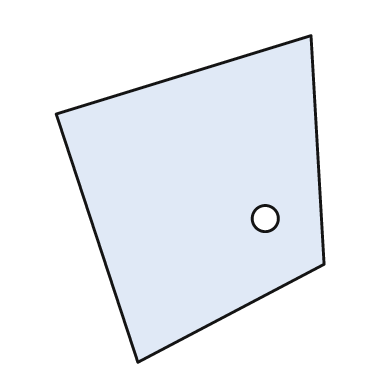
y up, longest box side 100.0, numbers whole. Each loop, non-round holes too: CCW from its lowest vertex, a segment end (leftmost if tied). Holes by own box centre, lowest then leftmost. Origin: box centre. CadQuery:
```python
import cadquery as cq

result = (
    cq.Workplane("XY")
    .moveTo(-16.0, -50.0)
    .lineTo(41.0, -20.0)
    .lineTo(37.0, 50.0)
    .lineTo(-41.0, 26.0)
    .close()
    .moveTo(23.0, -6.0)
    .circle(4.0)
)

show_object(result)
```